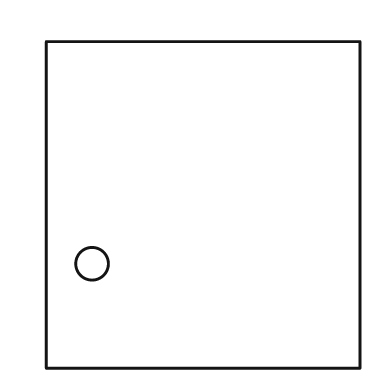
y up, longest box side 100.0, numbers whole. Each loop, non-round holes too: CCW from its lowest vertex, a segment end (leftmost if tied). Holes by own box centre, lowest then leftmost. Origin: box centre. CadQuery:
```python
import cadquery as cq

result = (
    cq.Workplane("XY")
    .moveTo(-48.0, -50.0)
    .lineTo(48.0, -50.0)
    .lineTo(48.0, 50.0)
    .lineTo(-48.0, 50.0)
    .close()
    .moveTo(-34.0, -18.0)
    .circle(5.0)
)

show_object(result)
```